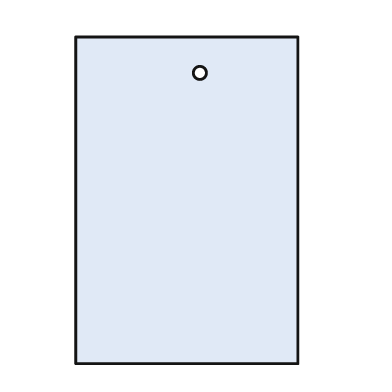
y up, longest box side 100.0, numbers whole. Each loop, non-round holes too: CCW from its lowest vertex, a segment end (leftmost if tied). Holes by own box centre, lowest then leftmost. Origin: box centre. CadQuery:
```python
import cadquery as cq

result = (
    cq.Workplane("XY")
    .moveTo(-34.0, -50.0)
    .lineTo(34.0, -50.0)
    .lineTo(34.0, 50.0)
    .lineTo(-34.0, 50.0)
    .close()
    .moveTo(4.0, 39.0)
    .circle(2.0)
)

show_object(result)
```